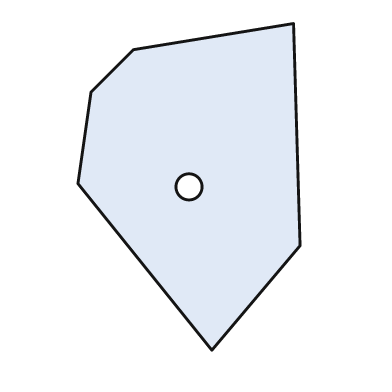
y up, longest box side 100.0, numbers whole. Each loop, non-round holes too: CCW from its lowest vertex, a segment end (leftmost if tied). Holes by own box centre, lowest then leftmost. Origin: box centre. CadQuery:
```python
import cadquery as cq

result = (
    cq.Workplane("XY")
    .moveTo(7.0, -50.0)
    .lineTo(34.0, -18.0)
    .lineTo(32.0, 50.0)
    .lineTo(-17.0, 42.0)
    .lineTo(-30.0, 29.0)
    .lineTo(-34.0, 1.0)
    .close()
    .moveTo(0.0, 0.0)
    .circle(4.0)
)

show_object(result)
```